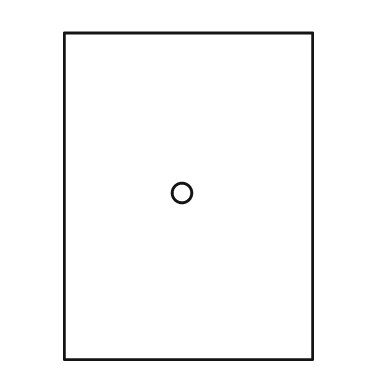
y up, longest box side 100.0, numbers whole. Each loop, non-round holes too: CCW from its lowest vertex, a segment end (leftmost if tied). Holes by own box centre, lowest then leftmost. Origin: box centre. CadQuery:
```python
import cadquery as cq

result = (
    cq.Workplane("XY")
    .moveTo(-38.0, -50.0)
    .lineTo(38.0, -50.0)
    .lineTo(38.0, 50.0)
    .lineTo(-38.0, 50.0)
    .close()
    .moveTo(-2.0, 1.0)
    .circle(3.0)
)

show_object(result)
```